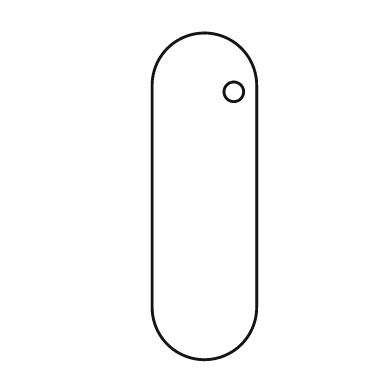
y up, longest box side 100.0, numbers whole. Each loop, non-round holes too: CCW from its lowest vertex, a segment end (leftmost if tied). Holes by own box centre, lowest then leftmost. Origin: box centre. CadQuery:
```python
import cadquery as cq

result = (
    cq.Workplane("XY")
    .moveTo(-16.0, -34.0)
    .threePointArc((0.0, -50.0), (16.0, -34.0))
    .lineTo(16.0, 34.0)
    .threePointArc((0.0, 50.0), (-16.0, 34.0))
    .close()
    .moveTo(9.0, 32.0)
    .circle(3.0)
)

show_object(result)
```